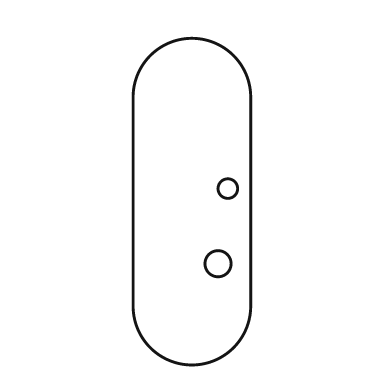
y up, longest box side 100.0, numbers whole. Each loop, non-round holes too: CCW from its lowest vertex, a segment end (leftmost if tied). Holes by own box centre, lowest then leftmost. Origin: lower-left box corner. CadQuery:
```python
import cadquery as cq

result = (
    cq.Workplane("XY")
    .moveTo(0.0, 18.0)
    .threePointArc((18.0, 0.0), (36.0, 18.0))
    .lineTo(36.0, 82.0)
    .threePointArc((18.0, 100.0), (0.0, 82.0))
    .close()
    .moveTo(26.0, 31.0)
    .circle(4.0)
    .moveTo(29.0, 54.0)
    .circle(3.0)
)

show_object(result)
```